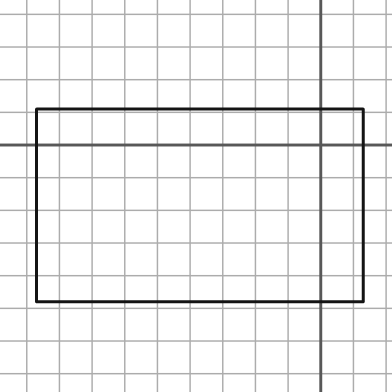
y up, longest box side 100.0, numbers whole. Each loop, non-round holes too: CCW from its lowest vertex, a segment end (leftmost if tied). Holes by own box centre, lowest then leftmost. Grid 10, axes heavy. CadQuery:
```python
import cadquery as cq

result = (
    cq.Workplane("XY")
    .moveTo(-87.0, -48.0)
    .lineTo(13.0, -48.0)
    .lineTo(13.0, 11.0)
    .lineTo(-87.0, 11.0)
    .close()
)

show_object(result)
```